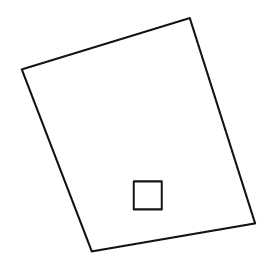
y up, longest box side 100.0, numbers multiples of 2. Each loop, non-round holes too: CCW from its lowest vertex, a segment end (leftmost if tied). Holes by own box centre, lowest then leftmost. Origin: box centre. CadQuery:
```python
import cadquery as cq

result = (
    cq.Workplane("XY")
    .moveTo(-20.0, -50.0)
    .lineTo(50.0, -38.0)
    .lineTo(22.0, 50.0)
    .lineTo(-50.0, 28.0)
    .close()
    .moveTo(-2.0, -32.0)
    .lineTo(10.0, -32.0)
    .lineTo(10.0, -20.0)
    .lineTo(-2.0, -20.0)
    .close()
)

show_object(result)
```